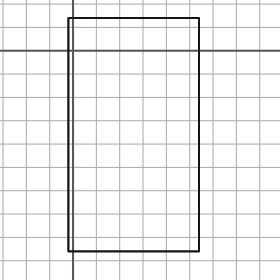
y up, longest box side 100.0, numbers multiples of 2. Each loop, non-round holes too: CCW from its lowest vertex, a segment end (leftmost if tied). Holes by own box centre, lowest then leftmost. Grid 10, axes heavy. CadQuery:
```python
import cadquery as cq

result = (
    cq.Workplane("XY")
    .moveTo(-2.0, -86.0)
    .lineTo(54.0, -86.0)
    .lineTo(54.0, 14.0)
    .lineTo(-2.0, 14.0)
    .close()
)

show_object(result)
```